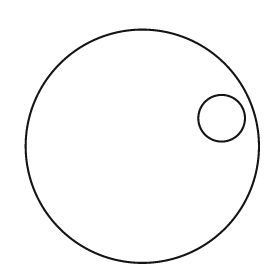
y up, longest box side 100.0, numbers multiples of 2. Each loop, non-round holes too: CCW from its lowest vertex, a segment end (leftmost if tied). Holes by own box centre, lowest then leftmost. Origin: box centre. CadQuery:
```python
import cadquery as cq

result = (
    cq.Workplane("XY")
    .moveTo(0.0, 0.0)
    .circle(50.0)
    .moveTo(34.0, 12.0)
    .circle(10.0)
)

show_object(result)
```